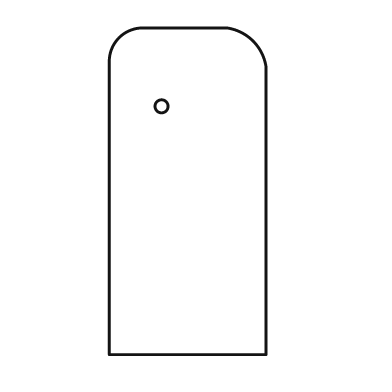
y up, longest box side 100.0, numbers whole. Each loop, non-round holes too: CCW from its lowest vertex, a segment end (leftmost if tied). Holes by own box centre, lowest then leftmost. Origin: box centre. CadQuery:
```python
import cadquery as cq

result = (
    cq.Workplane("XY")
    .moveTo(-24.0, -50.0)
    .lineTo(24.0, -50.0)
    .lineTo(24.0, 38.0)
    .threePointArc((20.0, 46.0), (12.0, 50.0))
    .lineTo(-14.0, 50.0)
    .threePointArc((-21.0, 47.0), (-24.0, 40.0))
    .close()
    .moveTo(-8.0, 26.0)
    .circle(2.0)
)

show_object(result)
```